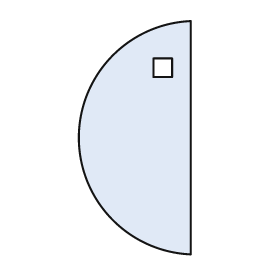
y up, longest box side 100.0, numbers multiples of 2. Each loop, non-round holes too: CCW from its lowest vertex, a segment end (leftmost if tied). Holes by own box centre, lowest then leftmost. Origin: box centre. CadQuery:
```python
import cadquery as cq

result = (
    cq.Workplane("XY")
    .moveTo(24.0, -50.0)
    .lineTo(24.0, 50.0)
    .threePointArc((-24.0, 0.0), (24.0, -50.0))
    .close()
    .moveTo(8.0, 26.0)
    .lineTo(16.0, 26.0)
    .lineTo(16.0, 34.0)
    .lineTo(8.0, 34.0)
    .close()
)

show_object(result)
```